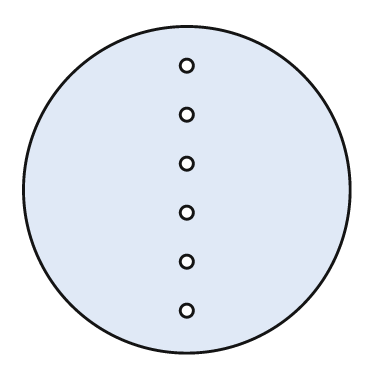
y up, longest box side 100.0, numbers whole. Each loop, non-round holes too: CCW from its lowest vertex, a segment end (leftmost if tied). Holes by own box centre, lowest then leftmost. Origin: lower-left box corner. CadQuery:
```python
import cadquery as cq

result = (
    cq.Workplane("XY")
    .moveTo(50.0, 50.0)
    .circle(50.0)
    .moveTo(50.0, 13.0)
    .circle(2.0)
    .moveTo(50.0, 28.0)
    .circle(2.0)
    .moveTo(50.0, 43.0)
    .circle(2.0)
    .moveTo(50.0, 58.0)
    .circle(2.0)
    .moveTo(50.0, 73.0)
    .circle(2.0)
    .moveTo(50.0, 88.0)
    .circle(2.0)
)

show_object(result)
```